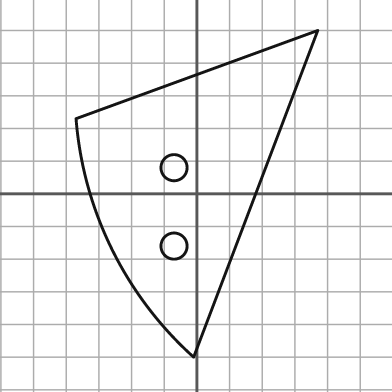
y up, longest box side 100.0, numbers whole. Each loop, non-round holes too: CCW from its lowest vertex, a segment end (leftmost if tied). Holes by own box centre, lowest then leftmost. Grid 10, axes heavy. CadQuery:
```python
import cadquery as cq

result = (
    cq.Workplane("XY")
    .moveTo(-1.0, -50.0)
    .lineTo(37.0, 50.0)
    .lineTo(-37.0, 23.0)
    .threePointArc((-26.0, -17.0), (-1.0, -50.0))
    .close()
    .moveTo(-7.0, -16.0)
    .circle(4.0)
    .moveTo(-7.0, 8.0)
    .circle(4.0)
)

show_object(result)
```